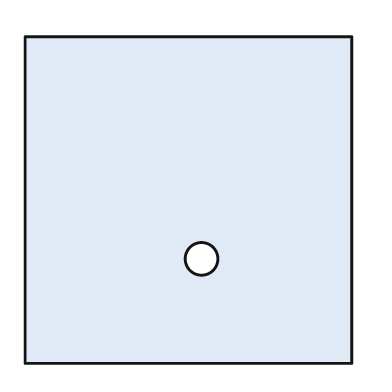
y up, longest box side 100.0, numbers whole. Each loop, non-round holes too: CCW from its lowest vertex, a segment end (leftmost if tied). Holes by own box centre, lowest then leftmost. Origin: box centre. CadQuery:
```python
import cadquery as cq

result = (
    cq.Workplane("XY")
    .moveTo(-50.0, -50.0)
    .lineTo(50.0, -50.0)
    .lineTo(50.0, 50.0)
    .lineTo(-50.0, 50.0)
    .close()
    .moveTo(4.0, -18.0)
    .circle(5.0)
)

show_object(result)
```